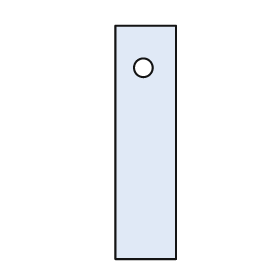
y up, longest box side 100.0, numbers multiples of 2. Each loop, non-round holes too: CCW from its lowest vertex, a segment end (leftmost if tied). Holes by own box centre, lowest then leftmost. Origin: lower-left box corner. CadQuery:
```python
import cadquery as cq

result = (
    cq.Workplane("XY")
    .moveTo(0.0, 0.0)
    .lineTo(26.0, 0.0)
    .lineTo(26.0, 100.0)
    .lineTo(0.0, 100.0)
    .close()
    .moveTo(12.0, 82.0)
    .circle(4.0)
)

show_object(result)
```